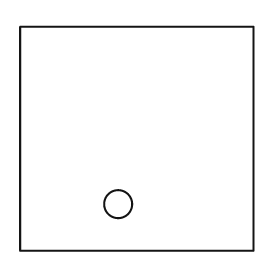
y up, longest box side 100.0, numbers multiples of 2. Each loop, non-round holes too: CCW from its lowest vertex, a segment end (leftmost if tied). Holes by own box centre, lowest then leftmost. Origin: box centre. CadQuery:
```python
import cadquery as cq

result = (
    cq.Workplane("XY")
    .moveTo(-50.0, -48.0)
    .lineTo(50.0, -48.0)
    .lineTo(50.0, 48.0)
    .lineTo(-50.0, 48.0)
    .close()
    .moveTo(-8.0, -28.0)
    .circle(6.0)
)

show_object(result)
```